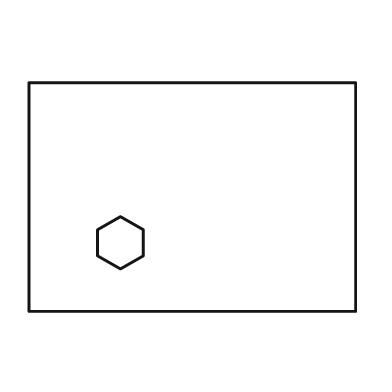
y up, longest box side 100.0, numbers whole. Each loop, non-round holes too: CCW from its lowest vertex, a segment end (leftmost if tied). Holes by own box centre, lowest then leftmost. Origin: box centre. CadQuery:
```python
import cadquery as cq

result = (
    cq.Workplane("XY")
    .moveTo(-50.0, -35.0)
    .lineTo(50.0, -35.0)
    .lineTo(50.0, 35.0)
    .lineTo(-50.0, 35.0)
    .close()
    .moveTo(-22.0, -22.0)
    .lineTo(-15.0, -18.0)
    .lineTo(-15.0, -10.0)
    .lineTo(-22.0, -6.0)
    .lineTo(-29.0, -10.0)
    .lineTo(-29.0, -18.0)
    .close()
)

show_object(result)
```